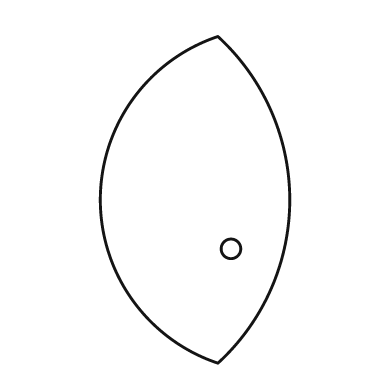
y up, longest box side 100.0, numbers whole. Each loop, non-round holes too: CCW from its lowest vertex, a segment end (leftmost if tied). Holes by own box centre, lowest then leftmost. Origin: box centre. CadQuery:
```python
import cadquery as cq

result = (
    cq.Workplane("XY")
    .moveTo(7.0, -50.0)
    .threePointArc((29.0, 0.0), (7.0, 50.0))
    .threePointArc((-29.0, 0.0), (7.0, -50.0))
    .close()
    .moveTo(11.0, -15.0)
    .circle(3.0)
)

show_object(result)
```